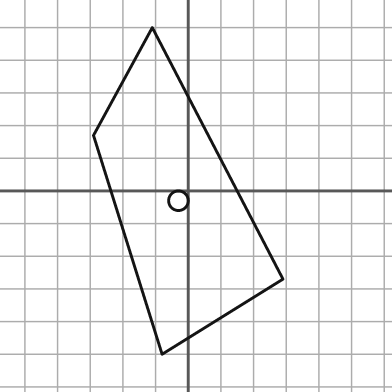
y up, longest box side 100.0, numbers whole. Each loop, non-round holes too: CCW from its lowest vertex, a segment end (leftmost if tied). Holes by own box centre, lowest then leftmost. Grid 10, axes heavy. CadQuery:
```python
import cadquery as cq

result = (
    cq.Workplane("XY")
    .moveTo(-8.0, -50.0)
    .lineTo(29.0, -27.0)
    .lineTo(-11.0, 50.0)
    .lineTo(-29.0, 17.0)
    .close()
    .moveTo(-3.0, -3.0)
    .circle(3.0)
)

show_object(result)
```